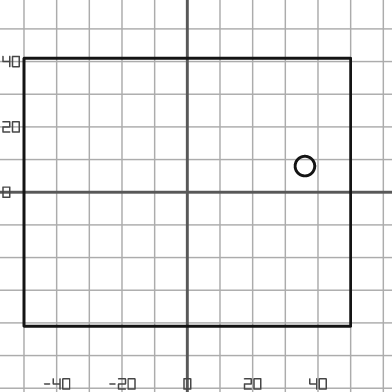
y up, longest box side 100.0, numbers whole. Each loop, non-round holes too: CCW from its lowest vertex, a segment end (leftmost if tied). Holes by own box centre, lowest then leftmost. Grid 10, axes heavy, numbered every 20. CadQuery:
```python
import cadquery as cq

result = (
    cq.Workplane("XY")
    .moveTo(-50.0, -41.0)
    .lineTo(50.0, -41.0)
    .lineTo(50.0, 41.0)
    .lineTo(-50.0, 41.0)
    .close()
    .moveTo(36.0, 8.0)
    .circle(3.0)
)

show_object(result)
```